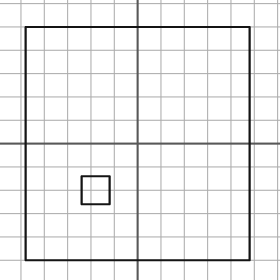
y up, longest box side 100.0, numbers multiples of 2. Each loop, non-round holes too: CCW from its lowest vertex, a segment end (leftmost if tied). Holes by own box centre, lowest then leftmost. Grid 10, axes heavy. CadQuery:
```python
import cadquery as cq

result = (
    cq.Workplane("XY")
    .moveTo(-48.0, -50.0)
    .lineTo(48.0, -50.0)
    .lineTo(48.0, 50.0)
    .lineTo(-48.0, 50.0)
    .close()
    .moveTo(-24.0, -26.0)
    .lineTo(-12.0, -26.0)
    .lineTo(-12.0, -14.0)
    .lineTo(-24.0, -14.0)
    .close()
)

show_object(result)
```